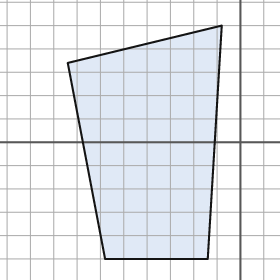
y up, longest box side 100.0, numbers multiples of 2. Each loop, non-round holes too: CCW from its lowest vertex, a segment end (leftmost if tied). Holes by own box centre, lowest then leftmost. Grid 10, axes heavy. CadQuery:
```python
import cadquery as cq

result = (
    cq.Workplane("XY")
    .moveTo(-58.0, -50.0)
    .lineTo(-14.0, -50.0)
    .lineTo(-8.0, 50.0)
    .lineTo(-74.0, 34.0)
    .close()
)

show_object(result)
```